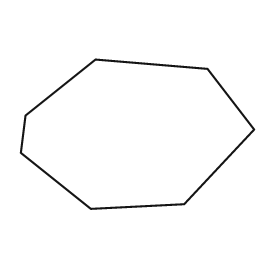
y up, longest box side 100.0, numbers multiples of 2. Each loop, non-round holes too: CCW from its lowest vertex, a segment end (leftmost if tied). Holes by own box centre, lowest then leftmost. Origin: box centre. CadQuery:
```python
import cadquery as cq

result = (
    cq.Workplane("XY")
    .moveTo(-20.0, -32.0)
    .lineTo(20.0, -30.0)
    .lineTo(50.0, 2.0)
    .lineTo(30.0, 28.0)
    .lineTo(-18.0, 32.0)
    .lineTo(-48.0, 8.0)
    .lineTo(-50.0, -8.0)
    .close()
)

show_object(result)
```